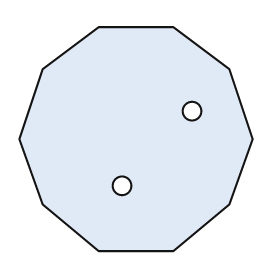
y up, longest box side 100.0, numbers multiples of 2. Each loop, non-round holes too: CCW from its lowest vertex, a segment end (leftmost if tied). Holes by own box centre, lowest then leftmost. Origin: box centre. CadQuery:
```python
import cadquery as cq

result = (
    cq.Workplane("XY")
    .moveTo(-16.0, -48.0)
    .lineTo(16.0, -48.0)
    .lineTo(40.0, -28.0)
    .lineTo(50.0, 0.0)
    .lineTo(40.0, 30.0)
    .lineTo(16.0, 48.0)
    .lineTo(-16.0, 48.0)
    .lineTo(-40.0, 30.0)
    .lineTo(-50.0, 0.0)
    .lineTo(-40.0, -28.0)
    .close()
    .moveTo(-6.0, -20.0)
    .circle(4.0)
    .moveTo(24.0, 12.0)
    .circle(4.0)
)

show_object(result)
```